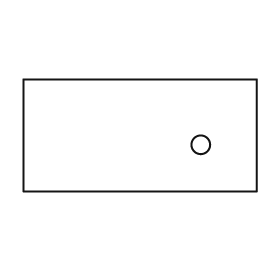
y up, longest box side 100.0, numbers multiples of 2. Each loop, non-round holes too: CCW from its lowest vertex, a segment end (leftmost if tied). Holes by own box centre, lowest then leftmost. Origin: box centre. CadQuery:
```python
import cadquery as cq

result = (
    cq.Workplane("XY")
    .moveTo(-50.0, -24.0)
    .lineTo(50.0, -24.0)
    .lineTo(50.0, 24.0)
    .lineTo(-50.0, 24.0)
    .close()
    .moveTo(26.0, -4.0)
    .circle(4.0)
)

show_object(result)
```